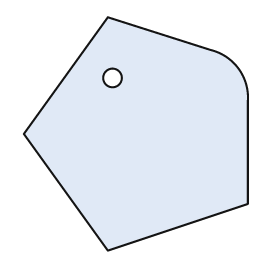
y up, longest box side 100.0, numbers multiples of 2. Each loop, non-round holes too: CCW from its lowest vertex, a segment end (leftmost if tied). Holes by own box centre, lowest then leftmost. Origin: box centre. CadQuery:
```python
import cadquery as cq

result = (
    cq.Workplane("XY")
    .moveTo(-12.0, -50.0)
    .lineTo(48.0, -30.0)
    .lineTo(48.0, 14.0)
    .threePointArc((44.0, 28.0), (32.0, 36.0))
    .lineTo(-12.0, 50.0)
    .lineTo(-48.0, 0.0)
    .close()
    .moveTo(-10.0, 24.0)
    .circle(4.0)
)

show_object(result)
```